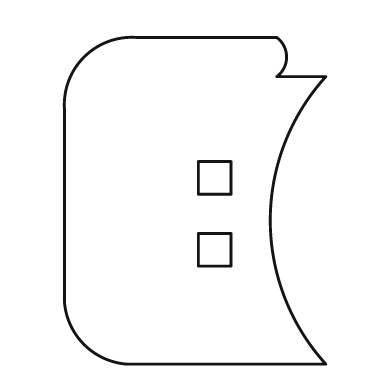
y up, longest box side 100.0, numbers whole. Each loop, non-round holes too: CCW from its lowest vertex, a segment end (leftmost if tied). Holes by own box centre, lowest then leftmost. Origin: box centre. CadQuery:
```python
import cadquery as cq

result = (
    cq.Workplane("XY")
    .moveTo(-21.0, -50.0)
    .lineTo(40.0, -50.0)
    .threePointArc((23.0, -6.0), (40.0, 38.0))
    .lineTo(25.0, 38.0)
    .threePointArc((28.0, 44.0), (25.0, 50.0))
    .lineTo(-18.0, 50.0)
    .threePointArc((-34.0, 44.0), (-40.0, 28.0))
    .lineTo(-40.0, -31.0)
    .threePointArc((-34.0, -44.0), (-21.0, -50.0))
    .close()
    .moveTo(1.0, -20.0)
    .lineTo(11.0, -20.0)
    .lineTo(11.0, -10.0)
    .lineTo(1.0, -10.0)
    .close()
    .moveTo(1.0, 2.0)
    .lineTo(11.0, 2.0)
    .lineTo(11.0, 12.0)
    .lineTo(1.0, 12.0)
    .close()
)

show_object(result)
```